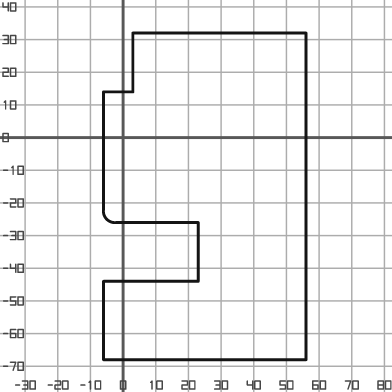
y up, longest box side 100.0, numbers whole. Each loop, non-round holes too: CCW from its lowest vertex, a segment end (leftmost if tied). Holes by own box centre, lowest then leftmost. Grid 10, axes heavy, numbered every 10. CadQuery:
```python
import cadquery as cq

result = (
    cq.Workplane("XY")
    .moveTo(-6.0, -68.0)
    .lineTo(56.0, -68.0)
    .lineTo(56.0, 32.0)
    .lineTo(3.0, 32.0)
    .lineTo(3.0, 14.0)
    .lineTo(-6.0, 14.0)
    .lineTo(-6.0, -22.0)
    .threePointArc((-5.0, -25.0), (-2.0, -26.0))
    .lineTo(23.0, -26.0)
    .lineTo(23.0, -44.0)
    .lineTo(-6.0, -44.0)
    .close()
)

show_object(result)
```